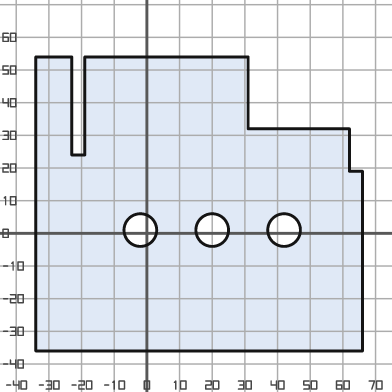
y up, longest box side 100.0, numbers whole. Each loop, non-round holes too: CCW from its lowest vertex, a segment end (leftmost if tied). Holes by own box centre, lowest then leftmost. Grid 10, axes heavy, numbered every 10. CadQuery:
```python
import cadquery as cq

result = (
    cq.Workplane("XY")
    .moveTo(-34.0, -36.0)
    .lineTo(66.0, -36.0)
    .lineTo(66.0, 19.0)
    .lineTo(62.0, 19.0)
    .lineTo(62.0, 32.0)
    .lineTo(31.0, 32.0)
    .lineTo(31.0, 54.0)
    .lineTo(-19.0, 54.0)
    .lineTo(-19.0, 24.0)
    .lineTo(-23.0, 24.0)
    .lineTo(-23.0, 54.0)
    .lineTo(-34.0, 54.0)
    .close()
    .moveTo(-2.0, 1.0)
    .circle(5.0)
    .moveTo(20.0, 1.0)
    .circle(5.0)
    .moveTo(42.0, 1.0)
    .circle(5.0)
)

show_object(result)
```